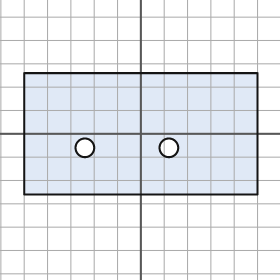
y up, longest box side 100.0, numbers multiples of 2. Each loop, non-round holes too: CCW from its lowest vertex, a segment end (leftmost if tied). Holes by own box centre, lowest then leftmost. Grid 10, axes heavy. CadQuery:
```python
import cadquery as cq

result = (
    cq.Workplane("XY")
    .moveTo(-50.0, -26.0)
    .lineTo(50.0, -26.0)
    .lineTo(50.0, 26.0)
    .lineTo(-50.0, 26.0)
    .close()
    .moveTo(-24.0, -6.0)
    .circle(4.0)
    .moveTo(12.0, -6.0)
    .circle(4.0)
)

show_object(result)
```